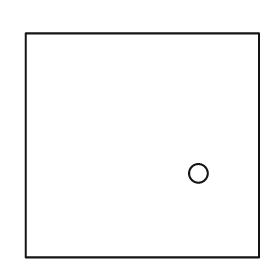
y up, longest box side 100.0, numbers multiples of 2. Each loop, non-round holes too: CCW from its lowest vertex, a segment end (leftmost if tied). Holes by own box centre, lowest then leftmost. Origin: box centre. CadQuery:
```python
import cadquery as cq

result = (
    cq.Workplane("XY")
    .moveTo(-50.0, -48.0)
    .lineTo(50.0, -48.0)
    .lineTo(50.0, 48.0)
    .lineTo(-50.0, 48.0)
    .close()
    .moveTo(24.0, -12.0)
    .circle(4.0)
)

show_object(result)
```